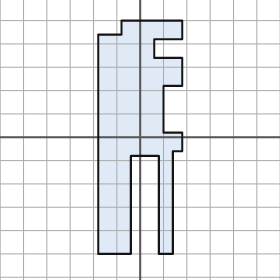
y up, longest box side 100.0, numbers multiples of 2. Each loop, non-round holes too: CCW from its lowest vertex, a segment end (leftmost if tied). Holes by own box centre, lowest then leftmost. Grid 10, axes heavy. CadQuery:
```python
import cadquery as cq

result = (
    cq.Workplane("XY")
    .moveTo(-18.0, -50.0)
    .lineTo(-4.0, -50.0)
    .lineTo(-4.0, -8.0)
    .lineTo(8.0, -8.0)
    .lineTo(8.0, -50.0)
    .lineTo(14.0, -50.0)
    .lineTo(14.0, -6.0)
    .lineTo(18.0, -6.0)
    .lineTo(18.0, 2.0)
    .lineTo(10.0, 2.0)
    .lineTo(10.0, 22.0)
    .lineTo(18.0, 22.0)
    .lineTo(18.0, 34.0)
    .lineTo(6.0, 34.0)
    .lineTo(6.0, 42.0)
    .lineTo(18.0, 42.0)
    .lineTo(18.0, 50.0)
    .lineTo(-8.0, 50.0)
    .lineTo(-8.0, 44.0)
    .lineTo(-18.0, 44.0)
    .close()
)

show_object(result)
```